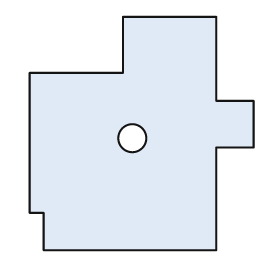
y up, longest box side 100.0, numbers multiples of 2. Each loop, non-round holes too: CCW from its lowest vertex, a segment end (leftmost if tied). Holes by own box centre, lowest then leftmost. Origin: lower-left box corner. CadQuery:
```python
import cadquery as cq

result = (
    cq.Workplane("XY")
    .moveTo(6.0, 0.0)
    .lineTo(80.0, 0.0)
    .lineTo(80.0, 44.0)
    .lineTo(96.0, 44.0)
    .lineTo(96.0, 64.0)
    .lineTo(80.0, 64.0)
    .lineTo(80.0, 100.0)
    .lineTo(40.0, 100.0)
    .lineTo(40.0, 76.0)
    .lineTo(0.0, 76.0)
    .lineTo(0.0, 16.0)
    .lineTo(6.0, 16.0)
    .close()
    .moveTo(44.0, 48.0)
    .circle(6.0)
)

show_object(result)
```